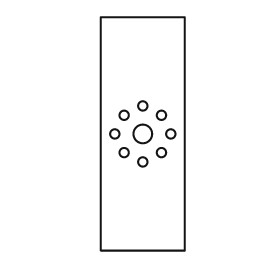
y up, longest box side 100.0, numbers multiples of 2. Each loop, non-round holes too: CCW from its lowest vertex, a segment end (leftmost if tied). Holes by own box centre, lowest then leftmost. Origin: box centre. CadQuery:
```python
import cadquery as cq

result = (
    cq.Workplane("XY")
    .moveTo(-18.0, -50.0)
    .lineTo(18.0, -50.0)
    .lineTo(18.0, 50.0)
    .lineTo(-18.0, 50.0)
    .close()
    .moveTo(0.0, -12.0)
    .circle(2.0)
    .moveTo(-8.0, -8.0)
    .circle(2.0)
    .moveTo(8.0, -8.0)
    .circle(2.0)
    .moveTo(-12.0, 0.0)
    .circle(2.0)
    .moveTo(0.0, 0.0)
    .circle(4.0)
    .moveTo(12.0, 0.0)
    .circle(2.0)
    .moveTo(-8.0, 8.0)
    .circle(2.0)
    .moveTo(8.0, 8.0)
    .circle(2.0)
    .moveTo(0.0, 12.0)
    .circle(2.0)
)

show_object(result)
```